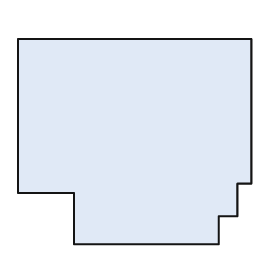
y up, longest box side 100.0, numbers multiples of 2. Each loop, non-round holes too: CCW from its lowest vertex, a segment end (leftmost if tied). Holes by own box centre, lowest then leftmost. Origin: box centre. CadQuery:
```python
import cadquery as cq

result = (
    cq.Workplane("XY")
    .moveTo(-26.0, -44.0)
    .lineTo(36.0, -44.0)
    .lineTo(36.0, -32.0)
    .lineTo(44.0, -32.0)
    .lineTo(44.0, -18.0)
    .lineTo(50.0, -18.0)
    .lineTo(50.0, 44.0)
    .lineTo(-50.0, 44.0)
    .lineTo(-50.0, -22.0)
    .lineTo(-26.0, -22.0)
    .close()
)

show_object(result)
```